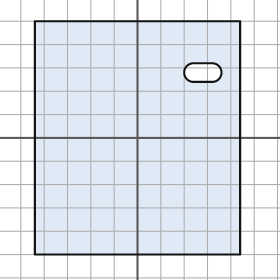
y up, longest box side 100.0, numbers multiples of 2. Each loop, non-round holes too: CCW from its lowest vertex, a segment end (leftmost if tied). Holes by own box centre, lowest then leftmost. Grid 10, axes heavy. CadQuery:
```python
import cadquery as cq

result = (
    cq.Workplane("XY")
    .moveTo(-44.0, -50.0)
    .lineTo(44.0, -50.0)
    .lineTo(44.0, 50.0)
    .lineTo(-44.0, 50.0)
    .close()
    .moveTo(24.0, 24.0)
    .lineTo(32.0, 24.0)
    .threePointArc((36.0, 28.0), (32.0, 32.0))
    .lineTo(24.0, 32.0)
    .threePointArc((20.0, 28.0), (24.0, 24.0))
    .close()
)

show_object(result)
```